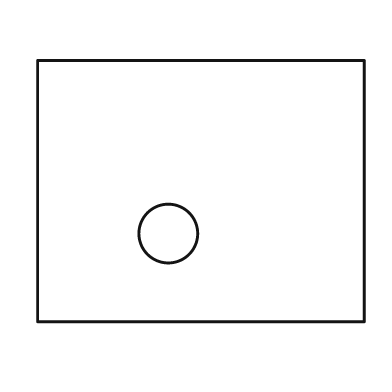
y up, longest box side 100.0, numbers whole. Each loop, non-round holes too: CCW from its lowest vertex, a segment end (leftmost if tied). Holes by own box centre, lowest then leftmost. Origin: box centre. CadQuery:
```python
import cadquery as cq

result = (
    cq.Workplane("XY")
    .moveTo(-50.0, -40.0)
    .lineTo(50.0, -40.0)
    .lineTo(50.0, 40.0)
    .lineTo(-50.0, 40.0)
    .close()
    .moveTo(-10.0, -13.0)
    .circle(9.0)
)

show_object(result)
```